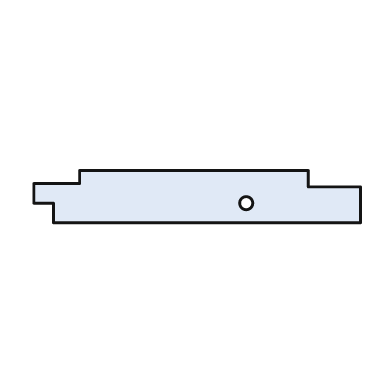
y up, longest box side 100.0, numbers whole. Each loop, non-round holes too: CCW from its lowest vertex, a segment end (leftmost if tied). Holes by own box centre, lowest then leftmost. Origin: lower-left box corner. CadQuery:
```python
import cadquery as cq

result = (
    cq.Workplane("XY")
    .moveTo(6.0, 0.0)
    .lineTo(100.0, 0.0)
    .lineTo(100.0, 11.0)
    .lineTo(84.0, 11.0)
    .lineTo(84.0, 16.0)
    .lineTo(14.0, 16.0)
    .lineTo(14.0, 12.0)
    .lineTo(0.0, 12.0)
    .lineTo(0.0, 6.0)
    .lineTo(6.0, 6.0)
    .close()
    .moveTo(65.0, 6.0)
    .circle(2.0)
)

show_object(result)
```